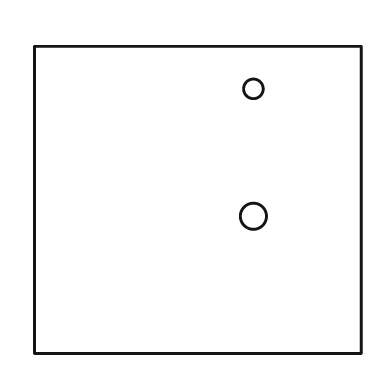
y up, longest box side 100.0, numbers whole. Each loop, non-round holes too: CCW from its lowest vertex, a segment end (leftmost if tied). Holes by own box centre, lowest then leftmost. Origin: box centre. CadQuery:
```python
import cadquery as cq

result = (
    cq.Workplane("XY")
    .moveTo(-50.0, -47.0)
    .lineTo(50.0, -47.0)
    .lineTo(50.0, 47.0)
    .lineTo(-50.0, 47.0)
    .close()
    .moveTo(17.0, -5.0)
    .circle(4.0)
    .moveTo(17.0, 34.0)
    .circle(3.0)
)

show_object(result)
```